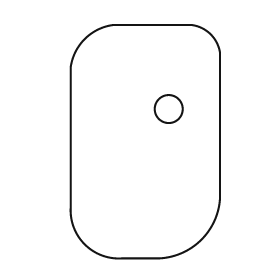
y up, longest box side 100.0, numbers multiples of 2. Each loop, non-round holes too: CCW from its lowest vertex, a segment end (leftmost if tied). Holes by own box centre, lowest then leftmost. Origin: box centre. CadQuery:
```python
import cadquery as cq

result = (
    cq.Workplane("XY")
    .moveTo(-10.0, -50.0)
    .lineTo(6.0, -50.0)
    .threePointArc((24.0, -42.0), (32.0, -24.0))
    .lineTo(32.0, 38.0)
    .threePointArc((28.0, 46.0), (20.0, 50.0))
    .lineTo(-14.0, 50.0)
    .threePointArc((-26.0, 44.0), (-32.0, 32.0))
    .lineTo(-32.0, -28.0)
    .threePointArc((-26.0, -44.0), (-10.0, -50.0))
    .close()
    .moveTo(10.0, 14.0)
    .circle(6.0)
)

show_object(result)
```